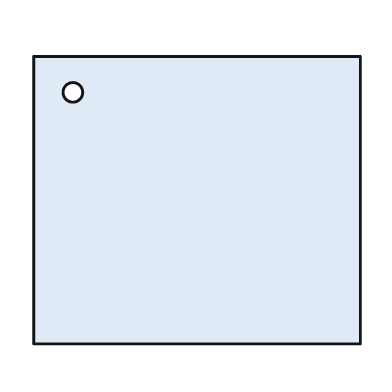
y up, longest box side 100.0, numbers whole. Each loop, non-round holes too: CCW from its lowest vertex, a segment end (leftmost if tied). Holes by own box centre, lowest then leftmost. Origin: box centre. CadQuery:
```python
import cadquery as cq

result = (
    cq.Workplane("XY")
    .moveTo(-50.0, -44.0)
    .lineTo(50.0, -44.0)
    .lineTo(50.0, 44.0)
    .lineTo(-50.0, 44.0)
    .close()
    .moveTo(-38.0, 33.0)
    .circle(3.0)
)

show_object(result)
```